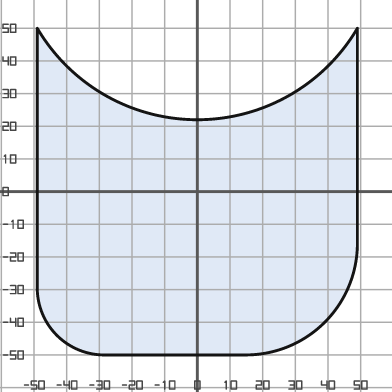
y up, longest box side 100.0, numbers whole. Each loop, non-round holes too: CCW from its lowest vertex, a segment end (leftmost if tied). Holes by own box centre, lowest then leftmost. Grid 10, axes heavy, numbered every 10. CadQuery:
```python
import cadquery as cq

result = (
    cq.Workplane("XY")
    .moveTo(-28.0, -50.0)
    .lineTo(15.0, -50.0)
    .threePointArc((39.0, -40.0), (49.0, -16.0))
    .lineTo(49.0, 50.0)
    .threePointArc((0.0, 22.0), (-49.0, 50.0))
    .lineTo(-49.0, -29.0)
    .threePointArc((-43.0, -44.0), (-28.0, -50.0))
    .close()
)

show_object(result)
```